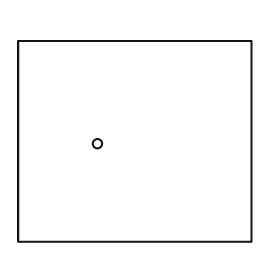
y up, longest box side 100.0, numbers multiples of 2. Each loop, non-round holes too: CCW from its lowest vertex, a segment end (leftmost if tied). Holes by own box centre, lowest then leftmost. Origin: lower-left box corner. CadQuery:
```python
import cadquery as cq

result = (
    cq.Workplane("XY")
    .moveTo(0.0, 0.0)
    .lineTo(100.0, 0.0)
    .lineTo(100.0, 86.0)
    .lineTo(0.0, 86.0)
    .close()
    .moveTo(34.0, 42.0)
    .circle(2.0)
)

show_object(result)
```